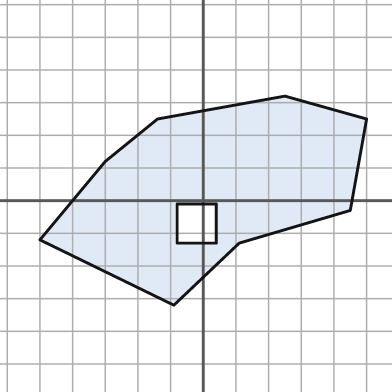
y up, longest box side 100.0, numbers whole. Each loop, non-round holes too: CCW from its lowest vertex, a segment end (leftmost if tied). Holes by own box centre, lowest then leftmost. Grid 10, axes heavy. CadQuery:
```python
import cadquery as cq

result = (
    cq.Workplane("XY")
    .moveTo(-9.0, -32.0)
    .lineTo(11.0, -13.0)
    .lineTo(45.0, -3.0)
    .lineTo(50.0, 25.0)
    .lineTo(25.0, 32.0)
    .lineTo(-14.0, 25.0)
    .lineTo(-30.0, 12.0)
    .lineTo(-50.0, -12.0)
    .close()
    .moveTo(-8.0, -13.0)
    .lineTo(4.0, -13.0)
    .lineTo(4.0, -1.0)
    .lineTo(-8.0, -1.0)
    .close()
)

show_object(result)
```